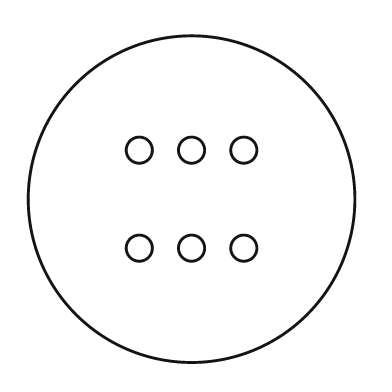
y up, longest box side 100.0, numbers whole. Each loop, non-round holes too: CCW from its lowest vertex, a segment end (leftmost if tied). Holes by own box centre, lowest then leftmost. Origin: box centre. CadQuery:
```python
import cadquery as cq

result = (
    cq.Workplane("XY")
    .moveTo(0.0, 0.0)
    .circle(50.0)
    .moveTo(-16.0, -15.0)
    .circle(4.0)
    .moveTo(0.0, -15.0)
    .circle(4.0)
    .moveTo(16.0, -15.0)
    .circle(4.0)
    .moveTo(-16.0, 15.0)
    .circle(4.0)
    .moveTo(0.0, 15.0)
    .circle(4.0)
    .moveTo(16.0, 15.0)
    .circle(4.0)
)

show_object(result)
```